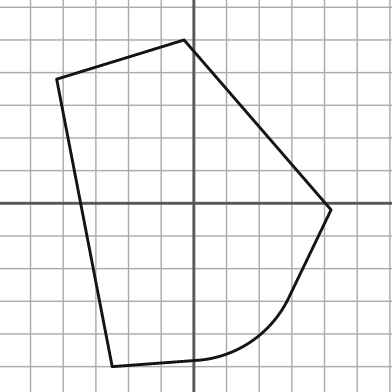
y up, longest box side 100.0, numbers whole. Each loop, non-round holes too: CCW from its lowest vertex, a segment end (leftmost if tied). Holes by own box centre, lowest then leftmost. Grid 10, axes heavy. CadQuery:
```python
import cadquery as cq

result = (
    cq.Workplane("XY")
    .moveTo(-25.0, -50.0)
    .lineTo(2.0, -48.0)
    .threePointArc((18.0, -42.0), (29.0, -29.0))
    .lineTo(42.0, -2.0)
    .lineTo(-3.0, 50.0)
    .lineTo(-42.0, 38.0)
    .close()
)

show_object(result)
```